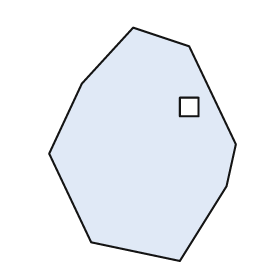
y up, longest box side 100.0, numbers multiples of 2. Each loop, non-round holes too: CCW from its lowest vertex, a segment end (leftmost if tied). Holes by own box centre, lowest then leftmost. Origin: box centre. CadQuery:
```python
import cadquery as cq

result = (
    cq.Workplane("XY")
    .moveTo(16.0, -50.0)
    .lineTo(36.0, -18.0)
    .lineTo(40.0, 0.0)
    .lineTo(20.0, 42.0)
    .lineTo(-4.0, 50.0)
    .lineTo(-26.0, 26.0)
    .lineTo(-40.0, -4.0)
    .lineTo(-22.0, -42.0)
    .close()
    .moveTo(16.0, 12.0)
    .lineTo(24.0, 12.0)
    .lineTo(24.0, 20.0)
    .lineTo(16.0, 20.0)
    .close()
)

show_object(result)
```